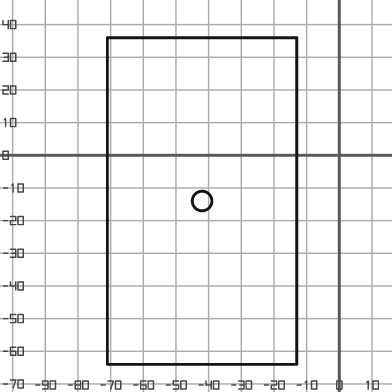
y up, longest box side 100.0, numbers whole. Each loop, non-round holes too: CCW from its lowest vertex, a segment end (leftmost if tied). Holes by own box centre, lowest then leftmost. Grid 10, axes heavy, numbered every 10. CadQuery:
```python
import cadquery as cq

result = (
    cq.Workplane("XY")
    .moveTo(-71.0, -64.0)
    .lineTo(-13.0, -64.0)
    .lineTo(-13.0, 36.0)
    .lineTo(-71.0, 36.0)
    .close()
    .moveTo(-42.0, -14.0)
    .circle(3.0)
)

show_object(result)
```